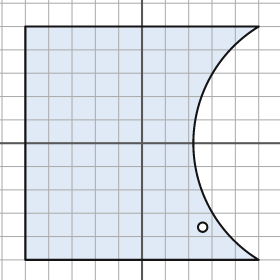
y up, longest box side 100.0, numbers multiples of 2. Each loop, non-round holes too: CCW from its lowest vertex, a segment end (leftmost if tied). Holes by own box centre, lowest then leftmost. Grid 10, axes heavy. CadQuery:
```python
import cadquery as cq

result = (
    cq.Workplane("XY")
    .moveTo(-50.0, -50.0)
    .lineTo(50.0, -50.0)
    .threePointArc((22.0, 0.0), (50.0, 50.0))
    .lineTo(-50.0, 50.0)
    .close()
    .moveTo(26.0, -36.0)
    .circle(2.0)
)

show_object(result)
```